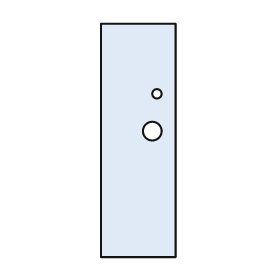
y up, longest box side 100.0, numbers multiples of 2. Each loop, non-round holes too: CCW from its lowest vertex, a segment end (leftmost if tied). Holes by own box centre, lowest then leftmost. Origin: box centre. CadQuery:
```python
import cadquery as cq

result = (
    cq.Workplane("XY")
    .moveTo(-16.0, -50.0)
    .lineTo(16.0, -50.0)
    .lineTo(16.0, 50.0)
    .lineTo(-16.0, 50.0)
    .close()
    .moveTo(6.0, 4.0)
    .circle(4.0)
    .moveTo(8.0, 20.0)
    .circle(2.0)
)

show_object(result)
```